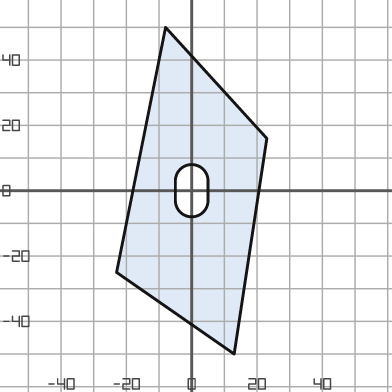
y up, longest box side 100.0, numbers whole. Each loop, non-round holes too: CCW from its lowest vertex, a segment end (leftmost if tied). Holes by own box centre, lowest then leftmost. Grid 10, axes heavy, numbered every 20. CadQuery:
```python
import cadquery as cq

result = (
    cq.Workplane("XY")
    .moveTo(13.0, -50.0)
    .lineTo(23.0, 16.0)
    .lineTo(-8.0, 50.0)
    .lineTo(-23.0, -25.0)
    .close()
    .moveTo(-5.0, -3.0)
    .threePointArc((0.0, -8.0), (5.0, -3.0))
    .lineTo(5.0, 3.0)
    .threePointArc((0.0, 8.0), (-5.0, 3.0))
    .close()
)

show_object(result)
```